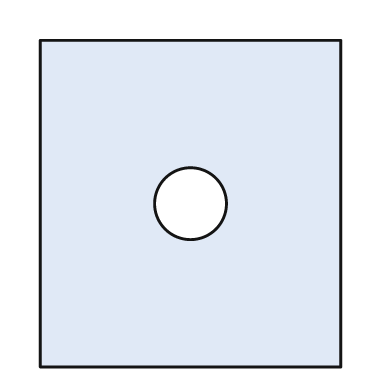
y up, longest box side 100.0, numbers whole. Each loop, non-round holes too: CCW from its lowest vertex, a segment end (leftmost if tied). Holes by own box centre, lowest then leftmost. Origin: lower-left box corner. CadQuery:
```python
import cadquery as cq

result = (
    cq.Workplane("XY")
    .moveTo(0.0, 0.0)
    .lineTo(92.0, 0.0)
    .lineTo(92.0, 100.0)
    .lineTo(0.0, 100.0)
    .close()
    .moveTo(46.0, 50.0)
    .circle(11.0)
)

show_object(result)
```